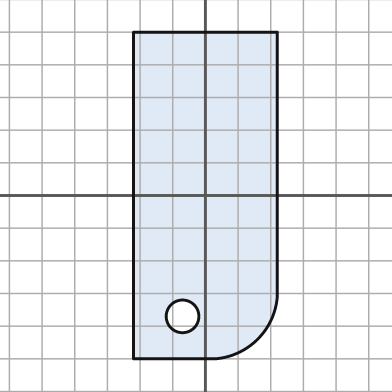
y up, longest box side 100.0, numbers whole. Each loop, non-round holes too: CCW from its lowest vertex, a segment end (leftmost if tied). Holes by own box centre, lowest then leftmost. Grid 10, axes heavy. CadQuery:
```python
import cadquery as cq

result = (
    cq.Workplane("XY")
    .moveTo(-22.0, -50.0)
    .lineTo(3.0, -50.0)
    .threePointArc((16.0, -44.0), (22.0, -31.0))
    .lineTo(22.0, 50.0)
    .lineTo(-22.0, 50.0)
    .close()
    .moveTo(-7.0, -37.0)
    .circle(5.0)
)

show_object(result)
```